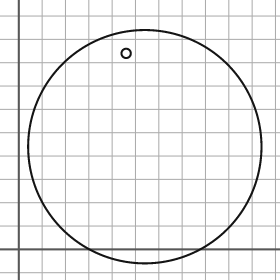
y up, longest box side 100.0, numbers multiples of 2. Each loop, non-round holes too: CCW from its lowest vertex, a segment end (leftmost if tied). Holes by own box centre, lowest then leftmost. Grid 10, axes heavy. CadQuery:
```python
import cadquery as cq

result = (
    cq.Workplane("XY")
    .moveTo(54.0, 44.0)
    .circle(50.0)
    .moveTo(46.0, 84.0)
    .circle(2.0)
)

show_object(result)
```